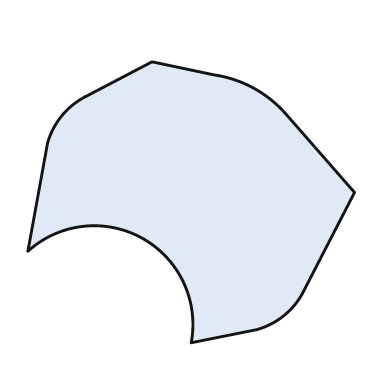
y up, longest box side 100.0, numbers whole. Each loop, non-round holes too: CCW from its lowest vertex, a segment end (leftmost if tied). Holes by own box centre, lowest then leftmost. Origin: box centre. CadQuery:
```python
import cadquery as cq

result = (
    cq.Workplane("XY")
    .moveTo(0.0, -43.0)
    .lineTo(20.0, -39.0)
    .threePointArc((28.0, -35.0), (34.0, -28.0))
    .lineTo(50.0, 3.0)
    .lineTo(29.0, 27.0)
    .threePointArc((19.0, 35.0), (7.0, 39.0))
    .lineTo(-12.0, 43.0)
    .lineTo(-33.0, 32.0)
    .threePointArc((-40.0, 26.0), (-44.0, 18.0))
    .lineTo(-50.0, -15.0)
    .threePointArc((-15.0, -11.0), (0.0, -43.0))
    .close()
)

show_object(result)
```